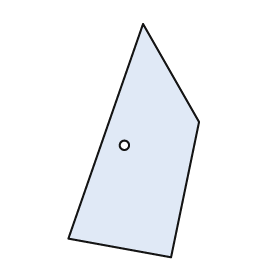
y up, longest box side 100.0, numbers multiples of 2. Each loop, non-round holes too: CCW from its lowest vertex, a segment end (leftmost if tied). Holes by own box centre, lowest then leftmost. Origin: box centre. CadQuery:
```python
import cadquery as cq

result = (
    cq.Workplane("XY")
    .moveTo(16.0, -50.0)
    .lineTo(28.0, 8.0)
    .lineTo(4.0, 50.0)
    .lineTo(-28.0, -42.0)
    .close()
    .moveTo(-4.0, -2.0)
    .circle(2.0)
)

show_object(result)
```